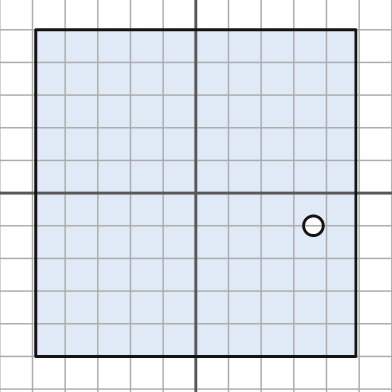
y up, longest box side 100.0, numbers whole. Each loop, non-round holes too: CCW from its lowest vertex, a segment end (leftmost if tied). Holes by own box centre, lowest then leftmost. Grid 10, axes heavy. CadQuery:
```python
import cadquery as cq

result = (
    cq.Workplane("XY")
    .moveTo(-49.0, -50.0)
    .lineTo(49.0, -50.0)
    .lineTo(49.0, 50.0)
    .lineTo(-49.0, 50.0)
    .close()
    .moveTo(36.0, -10.0)
    .circle(3.0)
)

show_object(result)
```